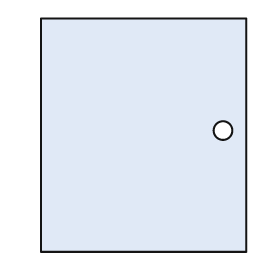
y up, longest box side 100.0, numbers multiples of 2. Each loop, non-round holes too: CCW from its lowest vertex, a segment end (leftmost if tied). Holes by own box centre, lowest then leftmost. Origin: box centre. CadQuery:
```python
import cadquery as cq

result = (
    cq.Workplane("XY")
    .moveTo(-44.0, -50.0)
    .lineTo(44.0, -50.0)
    .lineTo(44.0, 50.0)
    .lineTo(-44.0, 50.0)
    .close()
    .moveTo(34.0, 2.0)
    .circle(4.0)
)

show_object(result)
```